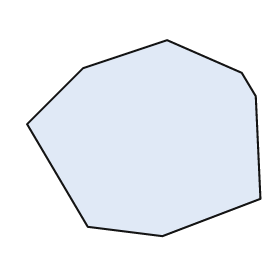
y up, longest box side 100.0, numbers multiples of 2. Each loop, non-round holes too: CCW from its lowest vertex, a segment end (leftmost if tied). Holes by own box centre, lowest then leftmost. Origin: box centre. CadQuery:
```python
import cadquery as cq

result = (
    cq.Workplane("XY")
    .moveTo(8.0, -42.0)
    .lineTo(50.0, -26.0)
    .lineTo(48.0, 18.0)
    .lineTo(42.0, 28.0)
    .lineTo(10.0, 42.0)
    .lineTo(-26.0, 30.0)
    .lineTo(-50.0, 6.0)
    .lineTo(-24.0, -38.0)
    .close()
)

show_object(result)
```